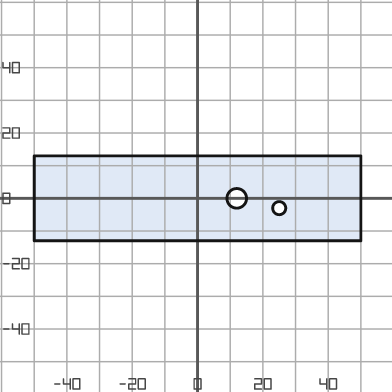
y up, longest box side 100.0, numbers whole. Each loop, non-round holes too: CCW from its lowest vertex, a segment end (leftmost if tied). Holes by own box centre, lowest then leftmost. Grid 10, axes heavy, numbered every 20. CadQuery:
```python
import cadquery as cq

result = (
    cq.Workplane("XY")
    .moveTo(-50.0, -13.0)
    .lineTo(50.0, -13.0)
    .lineTo(50.0, 13.0)
    .lineTo(-50.0, 13.0)
    .close()
    .moveTo(25.0, -3.0)
    .circle(2.0)
    .moveTo(12.0, 0.0)
    .circle(3.0)
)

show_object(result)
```